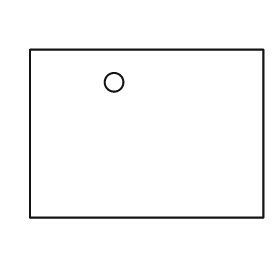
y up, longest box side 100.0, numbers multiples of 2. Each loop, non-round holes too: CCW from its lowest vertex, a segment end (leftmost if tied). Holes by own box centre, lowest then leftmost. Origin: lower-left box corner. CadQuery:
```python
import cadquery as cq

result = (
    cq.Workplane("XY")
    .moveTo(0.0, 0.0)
    .lineTo(100.0, 0.0)
    .lineTo(100.0, 72.0)
    .lineTo(0.0, 72.0)
    .close()
    .moveTo(36.0, 58.0)
    .circle(4.0)
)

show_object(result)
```